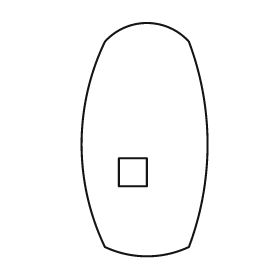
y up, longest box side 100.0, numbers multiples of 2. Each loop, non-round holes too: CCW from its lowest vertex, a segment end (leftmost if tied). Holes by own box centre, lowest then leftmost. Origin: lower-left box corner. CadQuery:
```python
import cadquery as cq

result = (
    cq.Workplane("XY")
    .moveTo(10.0, 4.0)
    .threePointArc((28.0, 0.0), (46.0, 4.0))
    .threePointArc((54.0, 48.0), (46.0, 92.0))
    .threePointArc((28.0, 100.0), (10.0, 92.0))
    .threePointArc((0.0, 48.0), (10.0, 4.0))
    .close()
    .moveTo(16.0, 30.0)
    .lineTo(28.0, 30.0)
    .lineTo(28.0, 42.0)
    .lineTo(16.0, 42.0)
    .close()
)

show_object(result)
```